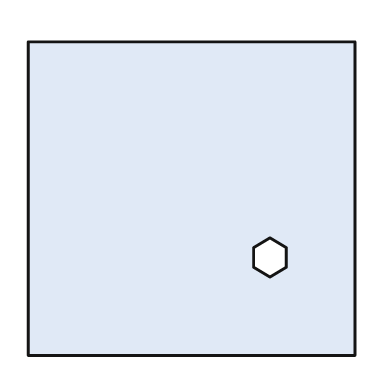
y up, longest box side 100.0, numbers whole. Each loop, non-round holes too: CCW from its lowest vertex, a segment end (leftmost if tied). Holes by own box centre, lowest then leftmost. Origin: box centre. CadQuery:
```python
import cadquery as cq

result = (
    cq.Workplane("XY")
    .moveTo(-50.0, -48.0)
    .lineTo(50.0, -48.0)
    .lineTo(50.0, 48.0)
    .lineTo(-50.0, 48.0)
    .close()
    .moveTo(24.0, -24.0)
    .lineTo(29.0, -21.0)
    .lineTo(29.0, -15.0)
    .lineTo(24.0, -12.0)
    .lineTo(19.0, -15.0)
    .lineTo(19.0, -21.0)
    .close()
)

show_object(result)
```